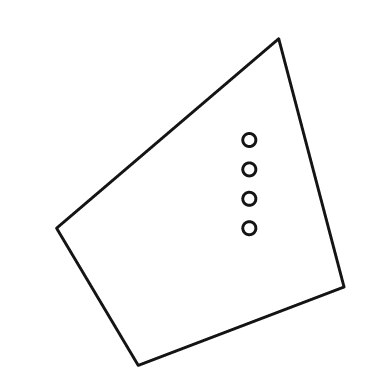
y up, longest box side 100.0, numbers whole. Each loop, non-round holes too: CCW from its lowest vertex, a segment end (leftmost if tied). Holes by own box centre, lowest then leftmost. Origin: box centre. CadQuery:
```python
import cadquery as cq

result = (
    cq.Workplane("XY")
    .moveTo(-19.0, -50.0)
    .lineTo(44.0, -26.0)
    .lineTo(24.0, 50.0)
    .lineTo(-44.0, -8.0)
    .close()
    .moveTo(15.0, -8.0)
    .circle(2.0)
    .moveTo(15.0, 1.0)
    .circle(2.0)
    .moveTo(15.0, 10.0)
    .circle(2.0)
    .moveTo(15.0, 19.0)
    .circle(2.0)
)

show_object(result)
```